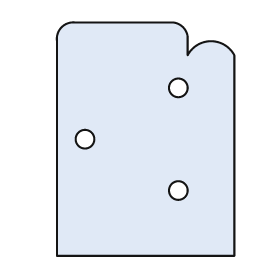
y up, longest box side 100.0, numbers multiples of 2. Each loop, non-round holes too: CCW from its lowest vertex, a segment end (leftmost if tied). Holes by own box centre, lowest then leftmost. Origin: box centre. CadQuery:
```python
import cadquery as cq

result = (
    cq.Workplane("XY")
    .moveTo(-38.0, -50.0)
    .lineTo(38.0, -50.0)
    .lineTo(38.0, 36.0)
    .threePointArc((28.0, 42.0), (18.0, 36.0))
    .lineTo(18.0, 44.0)
    .threePointArc((16.0, 48.0), (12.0, 50.0))
    .lineTo(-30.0, 50.0)
    .threePointArc((-36.0, 48.0), (-38.0, 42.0))
    .close()
    .moveTo(14.0, -22.0)
    .circle(4.0)
    .moveTo(-26.0, 0.0)
    .circle(4.0)
    .moveTo(14.0, 22.0)
    .circle(4.0)
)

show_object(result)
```